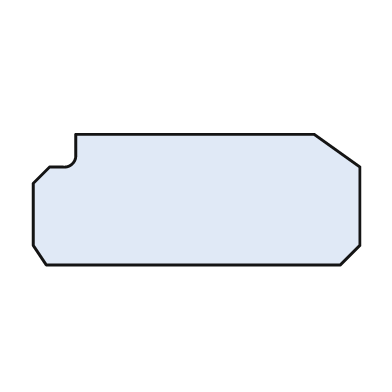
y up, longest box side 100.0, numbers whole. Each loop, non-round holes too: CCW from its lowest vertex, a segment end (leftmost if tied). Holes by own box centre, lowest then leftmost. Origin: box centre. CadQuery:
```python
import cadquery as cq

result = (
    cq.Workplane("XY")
    .moveTo(-46.0, -20.0)
    .lineTo(44.0, -20.0)
    .lineTo(50.0, -14.0)
    .lineTo(50.0, 10.0)
    .lineTo(36.0, 20.0)
    .lineTo(-37.0, 20.0)
    .lineTo(-37.0, 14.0)
    .threePointArc((-38.0, 11.0), (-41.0, 10.0))
    .lineTo(-45.0, 10.0)
    .lineTo(-50.0, 5.0)
    .lineTo(-50.0, -14.0)
    .close()
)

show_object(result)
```